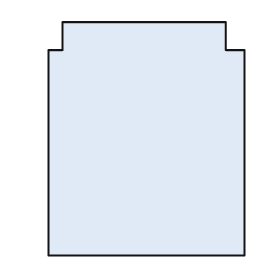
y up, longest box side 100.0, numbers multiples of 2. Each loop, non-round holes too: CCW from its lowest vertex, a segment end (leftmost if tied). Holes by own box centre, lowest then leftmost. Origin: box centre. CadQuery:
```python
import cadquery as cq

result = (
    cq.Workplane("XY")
    .moveTo(-42.0, -50.0)
    .lineTo(42.0, -50.0)
    .lineTo(42.0, 38.0)
    .lineTo(34.0, 38.0)
    .lineTo(34.0, 50.0)
    .lineTo(-36.0, 50.0)
    .lineTo(-36.0, 38.0)
    .lineTo(-42.0, 38.0)
    .close()
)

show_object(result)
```